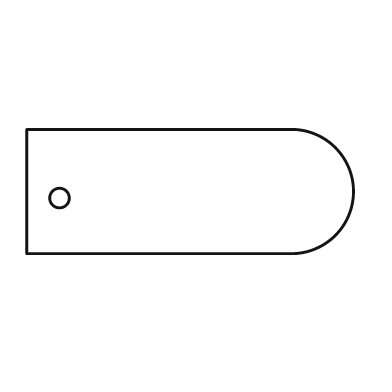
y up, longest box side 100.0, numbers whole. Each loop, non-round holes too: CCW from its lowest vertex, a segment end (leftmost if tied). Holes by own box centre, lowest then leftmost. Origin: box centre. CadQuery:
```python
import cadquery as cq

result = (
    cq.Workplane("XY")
    .moveTo(-50.0, -19.0)
    .lineTo(32.0, -19.0)
    .threePointArc((50.0, 0.0), (32.0, 19.0))
    .lineTo(-50.0, 19.0)
    .close()
    .moveTo(-40.0, -2.0)
    .circle(3.0)
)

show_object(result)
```